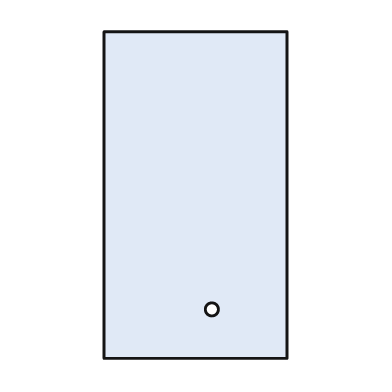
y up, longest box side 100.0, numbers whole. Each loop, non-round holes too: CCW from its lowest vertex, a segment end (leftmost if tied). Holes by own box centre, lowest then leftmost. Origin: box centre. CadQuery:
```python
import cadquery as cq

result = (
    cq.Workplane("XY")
    .moveTo(-28.0, -50.0)
    .lineTo(28.0, -50.0)
    .lineTo(28.0, 50.0)
    .lineTo(-28.0, 50.0)
    .close()
    .moveTo(5.0, -35.0)
    .circle(2.0)
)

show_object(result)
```